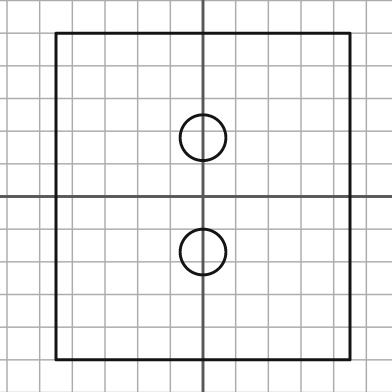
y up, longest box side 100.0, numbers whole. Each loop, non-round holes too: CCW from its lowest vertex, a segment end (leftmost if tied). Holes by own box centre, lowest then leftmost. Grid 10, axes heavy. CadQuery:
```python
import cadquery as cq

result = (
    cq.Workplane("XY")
    .moveTo(-45.0, -50.0)
    .lineTo(45.0, -50.0)
    .lineTo(45.0, 50.0)
    .lineTo(-45.0, 50.0)
    .close()
    .moveTo(0.0, -17.0)
    .circle(7.0)
    .moveTo(0.0, 18.0)
    .circle(7.0)
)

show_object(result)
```